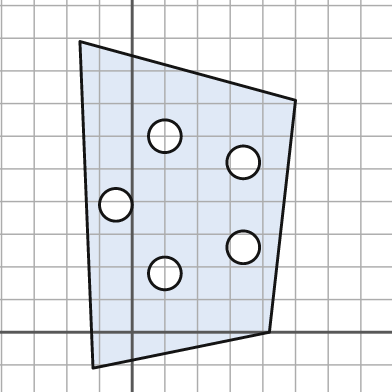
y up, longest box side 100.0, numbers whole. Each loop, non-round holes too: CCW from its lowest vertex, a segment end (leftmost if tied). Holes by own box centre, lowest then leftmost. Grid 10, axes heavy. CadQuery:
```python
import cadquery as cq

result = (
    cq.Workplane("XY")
    .moveTo(-12.0, -11.0)
    .lineTo(42.0, 0.0)
    .lineTo(50.0, 71.0)
    .lineTo(-16.0, 89.0)
    .close()
    .moveTo(10.0, 18.0)
    .circle(5.0)
    .moveTo(34.0, 26.0)
    .circle(5.0)
    .moveTo(-5.0, 39.0)
    .circle(5.0)
    .moveTo(34.0, 52.0)
    .circle(5.0)
    .moveTo(10.0, 60.0)
    .circle(5.0)
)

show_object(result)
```